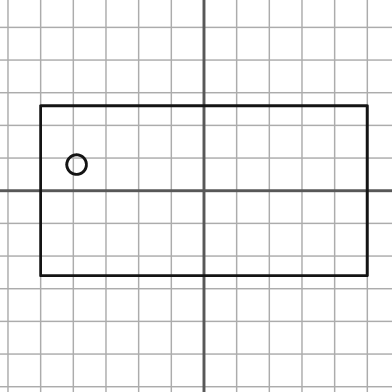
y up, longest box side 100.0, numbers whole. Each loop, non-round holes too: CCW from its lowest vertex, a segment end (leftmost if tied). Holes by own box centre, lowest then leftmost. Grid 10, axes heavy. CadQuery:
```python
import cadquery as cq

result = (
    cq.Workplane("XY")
    .moveTo(-50.0, -26.0)
    .lineTo(50.0, -26.0)
    .lineTo(50.0, 26.0)
    .lineTo(-50.0, 26.0)
    .close()
    .moveTo(-39.0, 8.0)
    .circle(3.0)
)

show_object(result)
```